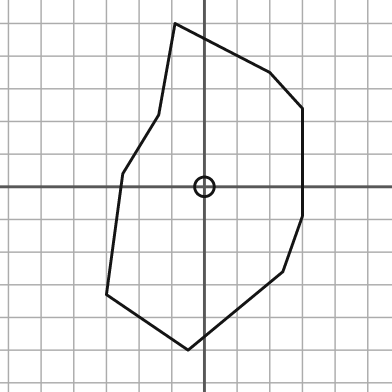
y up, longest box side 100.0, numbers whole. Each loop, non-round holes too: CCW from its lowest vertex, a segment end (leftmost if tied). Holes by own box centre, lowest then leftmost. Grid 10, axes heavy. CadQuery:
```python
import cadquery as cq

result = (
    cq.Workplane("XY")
    .moveTo(-5.0, -50.0)
    .lineTo(24.0, -26.0)
    .lineTo(30.0, -9.0)
    .lineTo(30.0, 24.0)
    .lineTo(20.0, 35.0)
    .lineTo(-9.0, 50.0)
    .lineTo(-14.0, 22.0)
    .lineTo(-25.0, 4.0)
    .lineTo(-30.0, -33.0)
    .close()
    .moveTo(0.0, 0.0)
    .circle(3.0)
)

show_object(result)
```